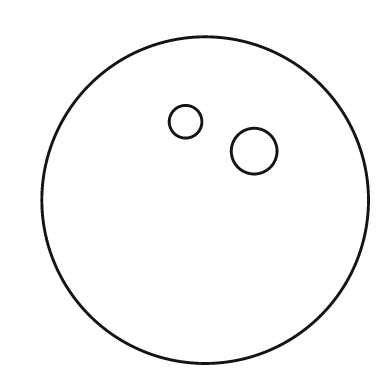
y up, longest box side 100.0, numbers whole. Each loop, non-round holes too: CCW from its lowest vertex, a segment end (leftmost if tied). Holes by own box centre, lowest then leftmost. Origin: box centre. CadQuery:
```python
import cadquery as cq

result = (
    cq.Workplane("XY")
    .moveTo(0.0, 0.0)
    .circle(50.0)
    .moveTo(15.0, 15.0)
    .circle(7.0)
    .moveTo(-6.0, 24.0)
    .circle(5.0)
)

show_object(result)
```